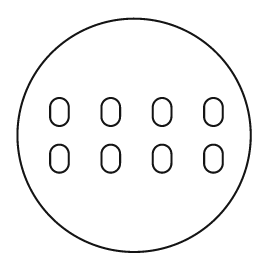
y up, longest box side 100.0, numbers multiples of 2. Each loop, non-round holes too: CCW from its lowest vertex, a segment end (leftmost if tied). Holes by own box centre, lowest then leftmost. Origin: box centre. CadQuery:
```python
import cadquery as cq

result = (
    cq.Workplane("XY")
    .moveTo(0.0, 0.0)
    .circle(50.0)
    .moveTo(-36.0, -12.0)
    .threePointArc((-32.0, -16.0), (-28.0, -12.0))
    .lineTo(-28.0, -8.0)
    .threePointArc((-32.0, -4.0), (-36.0, -8.0))
    .close()
    .moveTo(-14.0, -12.0)
    .threePointArc((-10.0, -16.0), (-6.0, -12.0))
    .lineTo(-6.0, -8.0)
    .threePointArc((-10.0, -4.0), (-14.0, -8.0))
    .close()
    .moveTo(8.0, -12.0)
    .threePointArc((12.0, -16.0), (16.0, -12.0))
    .lineTo(16.0, -8.0)
    .threePointArc((12.0, -4.0), (8.0, -8.0))
    .close()
    .moveTo(30.0, -12.0)
    .threePointArc((34.0, -16.0), (38.0, -12.0))
    .lineTo(38.0, -8.0)
    .threePointArc((34.0, -4.0), (30.0, -8.0))
    .close()
    .moveTo(-36.0, 8.0)
    .threePointArc((-32.0, 4.0), (-28.0, 8.0))
    .lineTo(-28.0, 12.0)
    .threePointArc((-32.0, 16.0), (-36.0, 12.0))
    .close()
    .moveTo(-14.0, 8.0)
    .threePointArc((-10.0, 4.0), (-6.0, 8.0))
    .lineTo(-6.0, 12.0)
    .threePointArc((-10.0, 16.0), (-14.0, 12.0))
    .close()
    .moveTo(8.0, 8.0)
    .threePointArc((12.0, 4.0), (16.0, 8.0))
    .lineTo(16.0, 12.0)
    .threePointArc((12.0, 16.0), (8.0, 12.0))
    .close()
    .moveTo(30.0, 8.0)
    .threePointArc((34.0, 4.0), (38.0, 8.0))
    .lineTo(38.0, 12.0)
    .threePointArc((34.0, 16.0), (30.0, 12.0))
    .close()
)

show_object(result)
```